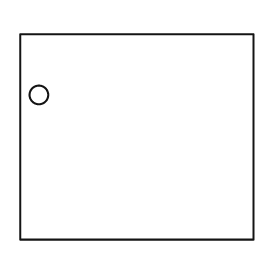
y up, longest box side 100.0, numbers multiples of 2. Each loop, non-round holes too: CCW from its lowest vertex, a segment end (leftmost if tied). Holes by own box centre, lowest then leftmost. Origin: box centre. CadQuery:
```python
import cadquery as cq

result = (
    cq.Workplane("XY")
    .moveTo(-50.0, -44.0)
    .lineTo(50.0, -44.0)
    .lineTo(50.0, 44.0)
    .lineTo(-50.0, 44.0)
    .close()
    .moveTo(-42.0, 18.0)
    .circle(4.0)
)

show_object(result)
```